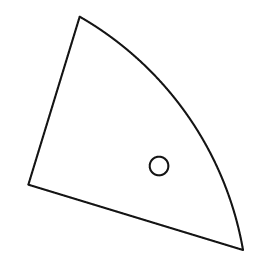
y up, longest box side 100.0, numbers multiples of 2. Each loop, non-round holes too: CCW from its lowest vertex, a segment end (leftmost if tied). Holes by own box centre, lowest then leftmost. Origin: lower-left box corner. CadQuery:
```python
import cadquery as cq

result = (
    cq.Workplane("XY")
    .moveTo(92.0, 0.0)
    .threePointArc((68.0, 58.0), (22.0, 100.0))
    .lineTo(0.0, 28.0)
    .close()
    .moveTo(56.0, 36.0)
    .circle(4.0)
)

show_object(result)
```